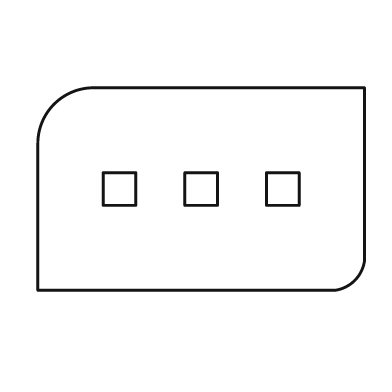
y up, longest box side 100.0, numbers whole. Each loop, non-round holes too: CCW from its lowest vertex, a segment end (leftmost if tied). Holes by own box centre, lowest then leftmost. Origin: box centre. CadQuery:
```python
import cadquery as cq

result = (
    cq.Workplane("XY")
    .moveTo(-50.0, -31.0)
    .lineTo(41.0, -31.0)
    .threePointArc((47.0, -28.0), (50.0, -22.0))
    .lineTo(50.0, 31.0)
    .lineTo(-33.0, 31.0)
    .threePointArc((-45.0, 26.0), (-50.0, 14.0))
    .close()
    .moveTo(-30.0, -5.0)
    .lineTo(-20.0, -5.0)
    .lineTo(-20.0, 5.0)
    .lineTo(-30.0, 5.0)
    .close()
    .moveTo(-5.0, -5.0)
    .lineTo(5.0, -5.0)
    .lineTo(5.0, 5.0)
    .lineTo(-5.0, 5.0)
    .close()
    .moveTo(20.0, -5.0)
    .lineTo(30.0, -5.0)
    .lineTo(30.0, 5.0)
    .lineTo(20.0, 5.0)
    .close()
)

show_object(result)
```